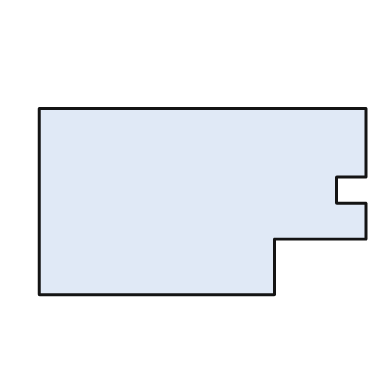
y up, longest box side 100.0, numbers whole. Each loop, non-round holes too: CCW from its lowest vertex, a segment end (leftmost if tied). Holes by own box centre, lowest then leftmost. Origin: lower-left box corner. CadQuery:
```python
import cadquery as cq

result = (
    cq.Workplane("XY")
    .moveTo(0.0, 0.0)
    .lineTo(72.0, 0.0)
    .lineTo(72.0, 17.0)
    .lineTo(100.0, 17.0)
    .lineTo(100.0, 28.0)
    .lineTo(91.0, 28.0)
    .lineTo(91.0, 36.0)
    .lineTo(100.0, 36.0)
    .lineTo(100.0, 57.0)
    .lineTo(0.0, 57.0)
    .close()
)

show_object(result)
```